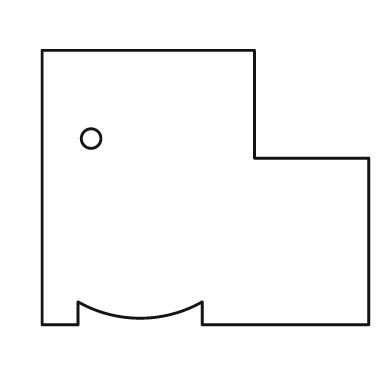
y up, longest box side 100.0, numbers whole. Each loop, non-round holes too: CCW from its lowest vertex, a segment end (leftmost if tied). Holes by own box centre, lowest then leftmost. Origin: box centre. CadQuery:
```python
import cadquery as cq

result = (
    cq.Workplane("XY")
    .moveTo(-50.0, -42.0)
    .lineTo(-39.0, -42.0)
    .lineTo(-39.0, -35.0)
    .threePointArc((-20.0, -40.0), (-1.0, -35.0))
    .lineTo(-1.0, -42.0)
    .lineTo(50.0, -42.0)
    .lineTo(50.0, 9.0)
    .lineTo(15.0, 9.0)
    .lineTo(15.0, 42.0)
    .lineTo(-50.0, 42.0)
    .close()
    .moveTo(-35.0, 15.0)
    .circle(3.0)
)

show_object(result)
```